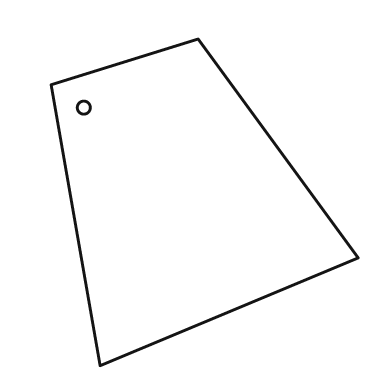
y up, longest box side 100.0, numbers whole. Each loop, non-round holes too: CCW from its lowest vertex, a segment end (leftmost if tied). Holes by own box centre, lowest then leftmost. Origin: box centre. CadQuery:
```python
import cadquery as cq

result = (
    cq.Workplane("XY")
    .moveTo(-32.0, -50.0)
    .lineTo(47.0, -17.0)
    .lineTo(-2.0, 50.0)
    .lineTo(-47.0, 36.0)
    .close()
    .moveTo(-37.0, 29.0)
    .circle(2.0)
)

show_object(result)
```